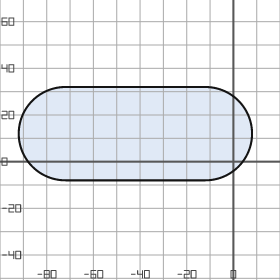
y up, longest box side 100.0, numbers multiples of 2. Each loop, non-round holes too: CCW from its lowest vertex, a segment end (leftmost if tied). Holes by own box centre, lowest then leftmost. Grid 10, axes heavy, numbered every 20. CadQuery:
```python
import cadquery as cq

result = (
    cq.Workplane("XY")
    .moveTo(-72.0, -8.0)
    .lineTo(-12.0, -8.0)
    .threePointArc((8.0, 12.0), (-12.0, 32.0))
    .lineTo(-72.0, 32.0)
    .threePointArc((-92.0, 12.0), (-72.0, -8.0))
    .close()
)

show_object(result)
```